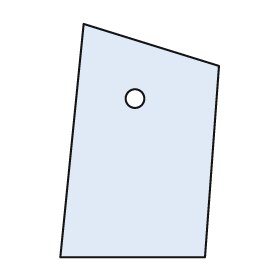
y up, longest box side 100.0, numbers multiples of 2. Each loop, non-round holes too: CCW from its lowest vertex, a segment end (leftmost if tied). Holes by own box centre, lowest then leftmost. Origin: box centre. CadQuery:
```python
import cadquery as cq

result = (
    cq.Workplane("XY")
    .moveTo(-34.0, -50.0)
    .lineTo(28.0, -50.0)
    .lineTo(34.0, 32.0)
    .lineTo(-24.0, 50.0)
    .close()
    .moveTo(-2.0, 18.0)
    .circle(4.0)
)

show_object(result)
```